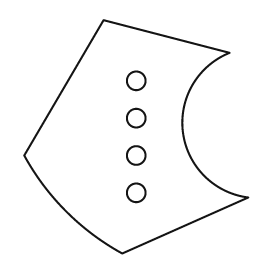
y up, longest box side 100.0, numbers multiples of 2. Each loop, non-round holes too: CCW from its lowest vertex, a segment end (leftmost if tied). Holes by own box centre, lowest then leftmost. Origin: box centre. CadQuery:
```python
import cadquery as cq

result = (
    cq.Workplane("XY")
    .moveTo(-6.0, -50.0)
    .lineTo(48.0, -26.0)
    .threePointArc((20.0, 2.0), (40.0, 36.0))
    .lineTo(-14.0, 50.0)
    .lineTo(-48.0, -8.0)
    .threePointArc((-30.0, -32.0), (-6.0, -50.0))
    .close()
    .moveTo(0.0, -24.0)
    .circle(4.0)
    .moveTo(0.0, -8.0)
    .circle(4.0)
    .moveTo(0.0, 8.0)
    .circle(4.0)
    .moveTo(0.0, 24.0)
    .circle(4.0)
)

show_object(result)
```